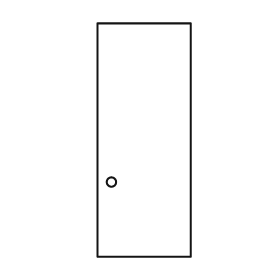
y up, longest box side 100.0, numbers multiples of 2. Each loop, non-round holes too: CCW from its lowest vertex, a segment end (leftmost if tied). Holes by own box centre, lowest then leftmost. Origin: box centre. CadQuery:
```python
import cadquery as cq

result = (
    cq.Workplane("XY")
    .moveTo(-20.0, -50.0)
    .lineTo(20.0, -50.0)
    .lineTo(20.0, 50.0)
    .lineTo(-20.0, 50.0)
    .close()
    .moveTo(-14.0, -18.0)
    .circle(2.0)
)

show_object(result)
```